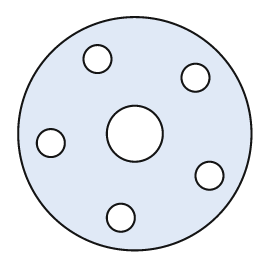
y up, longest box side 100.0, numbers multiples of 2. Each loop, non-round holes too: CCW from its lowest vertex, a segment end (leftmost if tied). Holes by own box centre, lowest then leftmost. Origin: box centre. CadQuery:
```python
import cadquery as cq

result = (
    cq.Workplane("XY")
    .moveTo(0.0, 0.0)
    .circle(50.0)
    .moveTo(-6.0, -36.0)
    .circle(6.0)
    .moveTo(32.0, -18.0)
    .circle(6.0)
    .moveTo(-36.0, -4.0)
    .circle(6.0)
    .moveTo(0.0, 0.0)
    .circle(12.0)
    .moveTo(26.0, 24.0)
    .circle(6.0)
    .moveTo(-16.0, 32.0)
    .circle(6.0)
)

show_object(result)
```